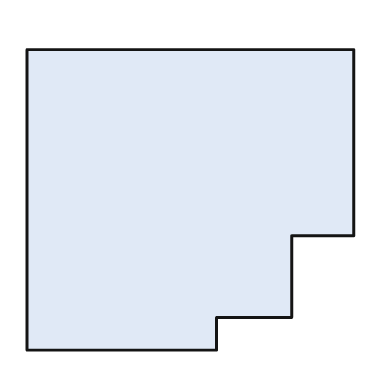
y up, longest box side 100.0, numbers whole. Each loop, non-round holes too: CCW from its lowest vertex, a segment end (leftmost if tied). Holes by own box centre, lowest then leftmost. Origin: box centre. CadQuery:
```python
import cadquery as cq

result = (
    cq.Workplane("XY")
    .moveTo(-50.0, -46.0)
    .lineTo(8.0, -46.0)
    .lineTo(8.0, -36.0)
    .lineTo(31.0, -36.0)
    .lineTo(31.0, -11.0)
    .lineTo(50.0, -11.0)
    .lineTo(50.0, 46.0)
    .lineTo(-50.0, 46.0)
    .close()
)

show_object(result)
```